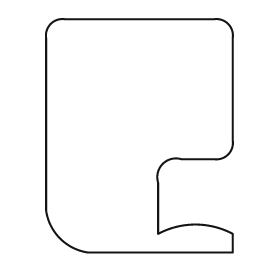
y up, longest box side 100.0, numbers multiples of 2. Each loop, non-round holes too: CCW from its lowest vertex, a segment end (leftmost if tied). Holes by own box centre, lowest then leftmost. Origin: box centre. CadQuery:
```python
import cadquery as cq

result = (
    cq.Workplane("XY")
    .moveTo(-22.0, -50.0)
    .lineTo(40.0, -50.0)
    .lineTo(40.0, -42.0)
    .threePointArc((24.0, -38.0), (8.0, -42.0))
    .lineTo(8.0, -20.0)
    .threePointArc((10.0, -12.0), (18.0, -10.0))
    .lineTo(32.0, -10.0)
    .threePointArc((38.0, -8.0), (40.0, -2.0))
    .lineTo(40.0, 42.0)
    .threePointArc((38.0, 48.0), (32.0, 50.0))
    .lineTo(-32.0, 50.0)
    .threePointArc((-38.0, 48.0), (-40.0, 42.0))
    .lineTo(-40.0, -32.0)
    .threePointArc((-34.0, -44.0), (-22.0, -50.0))
    .close()
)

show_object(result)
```